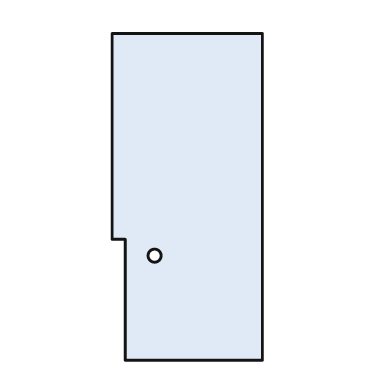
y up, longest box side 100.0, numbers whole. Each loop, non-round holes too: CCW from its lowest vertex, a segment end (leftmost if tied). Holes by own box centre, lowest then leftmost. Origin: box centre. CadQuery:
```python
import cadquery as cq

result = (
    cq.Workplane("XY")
    .moveTo(-19.0, -50.0)
    .lineTo(23.0, -50.0)
    .lineTo(23.0, 50.0)
    .lineTo(-23.0, 50.0)
    .lineTo(-23.0, -13.0)
    .lineTo(-19.0, -13.0)
    .close()
    .moveTo(-10.0, -18.0)
    .circle(2.0)
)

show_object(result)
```